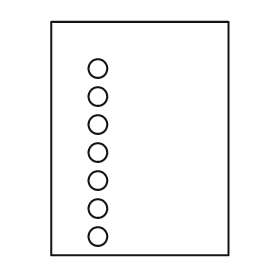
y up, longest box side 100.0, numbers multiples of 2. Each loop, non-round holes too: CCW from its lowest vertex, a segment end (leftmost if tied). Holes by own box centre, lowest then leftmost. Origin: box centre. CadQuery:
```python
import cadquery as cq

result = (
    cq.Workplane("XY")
    .moveTo(-38.0, -50.0)
    .lineTo(38.0, -50.0)
    .lineTo(38.0, 50.0)
    .lineTo(-38.0, 50.0)
    .close()
    .moveTo(-18.0, -42.0)
    .circle(4.0)
    .moveTo(-18.0, -30.0)
    .circle(4.0)
    .moveTo(-18.0, -18.0)
    .circle(4.0)
    .moveTo(-18.0, -6.0)
    .circle(4.0)
    .moveTo(-18.0, 6.0)
    .circle(4.0)
    .moveTo(-18.0, 18.0)
    .circle(4.0)
    .moveTo(-18.0, 30.0)
    .circle(4.0)
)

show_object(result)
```